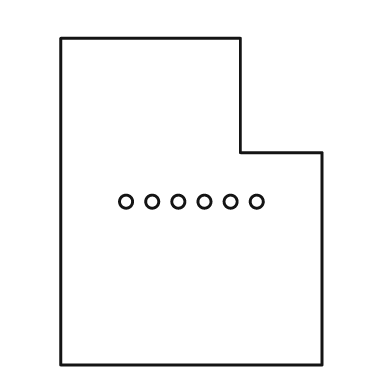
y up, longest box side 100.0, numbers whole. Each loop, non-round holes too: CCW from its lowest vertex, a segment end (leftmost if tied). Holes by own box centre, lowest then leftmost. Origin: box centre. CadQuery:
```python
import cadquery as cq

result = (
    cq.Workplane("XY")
    .moveTo(-40.0, -50.0)
    .lineTo(40.0, -50.0)
    .lineTo(40.0, 15.0)
    .lineTo(15.0, 15.0)
    .lineTo(15.0, 50.0)
    .lineTo(-40.0, 50.0)
    .close()
    .moveTo(-20.0, 0.0)
    .circle(2.0)
    .moveTo(-12.0, 0.0)
    .circle(2.0)
    .moveTo(-4.0, 0.0)
    .circle(2.0)
    .moveTo(4.0, 0.0)
    .circle(2.0)
    .moveTo(12.0, 0.0)
    .circle(2.0)
    .moveTo(20.0, 0.0)
    .circle(2.0)
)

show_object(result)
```